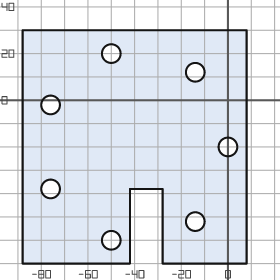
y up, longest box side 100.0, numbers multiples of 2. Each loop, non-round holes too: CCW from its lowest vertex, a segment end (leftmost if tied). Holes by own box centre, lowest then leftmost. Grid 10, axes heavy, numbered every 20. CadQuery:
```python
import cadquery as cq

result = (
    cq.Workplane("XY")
    .moveTo(-88.0, -70.0)
    .lineTo(-42.0, -70.0)
    .lineTo(-42.0, -38.0)
    .lineTo(-28.0, -38.0)
    .lineTo(-28.0, -70.0)
    .lineTo(8.0, -70.0)
    .lineTo(8.0, 30.0)
    .lineTo(-88.0, 30.0)
    .close()
    .moveTo(-50.0, -60.0)
    .circle(4.0)
    .moveTo(-14.0, -52.0)
    .circle(4.0)
    .moveTo(-76.0, -38.0)
    .circle(4.0)
    .moveTo(0.0, -20.0)
    .circle(4.0)
    .moveTo(-76.0, -2.0)
    .circle(4.0)
    .moveTo(-14.0, 12.0)
    .circle(4.0)
    .moveTo(-50.0, 20.0)
    .circle(4.0)
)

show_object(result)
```